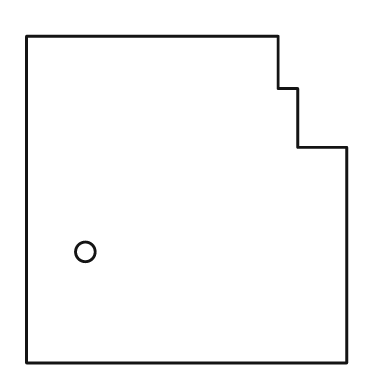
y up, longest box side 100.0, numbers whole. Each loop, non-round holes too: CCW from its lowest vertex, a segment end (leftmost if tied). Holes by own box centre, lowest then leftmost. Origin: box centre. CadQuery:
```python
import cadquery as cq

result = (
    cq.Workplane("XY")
    .moveTo(-49.0, -50.0)
    .lineTo(49.0, -50.0)
    .lineTo(49.0, 16.0)
    .lineTo(34.0, 16.0)
    .lineTo(34.0, 34.0)
    .lineTo(28.0, 34.0)
    .lineTo(28.0, 50.0)
    .lineTo(-49.0, 50.0)
    .close()
    .moveTo(-31.0, -16.0)
    .circle(3.0)
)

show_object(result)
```